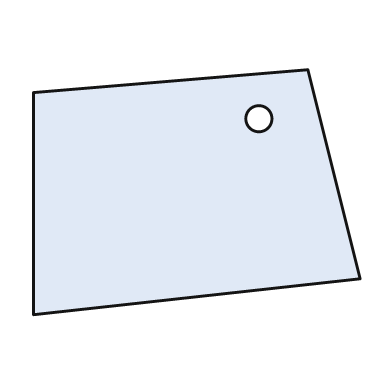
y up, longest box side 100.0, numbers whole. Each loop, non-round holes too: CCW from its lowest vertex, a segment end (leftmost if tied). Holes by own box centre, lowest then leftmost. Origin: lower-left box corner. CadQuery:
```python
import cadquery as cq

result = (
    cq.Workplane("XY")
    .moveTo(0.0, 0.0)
    .lineTo(100.0, 11.0)
    .lineTo(84.0, 75.0)
    .lineTo(0.0, 68.0)
    .close()
    .moveTo(69.0, 60.0)
    .circle(4.0)
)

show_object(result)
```